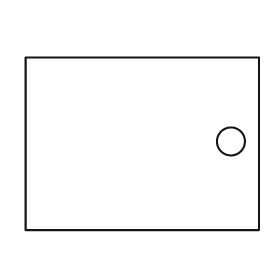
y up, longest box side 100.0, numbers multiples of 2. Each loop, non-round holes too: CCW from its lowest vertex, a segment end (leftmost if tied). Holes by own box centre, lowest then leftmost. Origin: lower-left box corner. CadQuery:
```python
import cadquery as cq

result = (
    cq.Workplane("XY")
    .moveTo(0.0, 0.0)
    .lineTo(100.0, 0.0)
    .lineTo(100.0, 74.0)
    .lineTo(0.0, 74.0)
    .close()
    .moveTo(88.0, 38.0)
    .circle(6.0)
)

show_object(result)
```